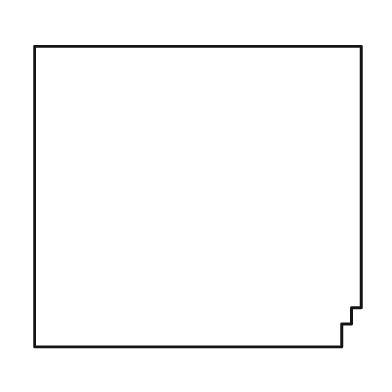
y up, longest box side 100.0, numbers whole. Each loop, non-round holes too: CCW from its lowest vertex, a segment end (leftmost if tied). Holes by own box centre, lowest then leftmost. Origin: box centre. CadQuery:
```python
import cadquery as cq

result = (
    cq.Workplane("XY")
    .moveTo(-50.0, -46.0)
    .lineTo(44.0, -46.0)
    .lineTo(44.0, -39.0)
    .lineTo(47.0, -39.0)
    .lineTo(47.0, -34.0)
    .lineTo(50.0, -34.0)
    .lineTo(50.0, 46.0)
    .lineTo(-50.0, 46.0)
    .close()
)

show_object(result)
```